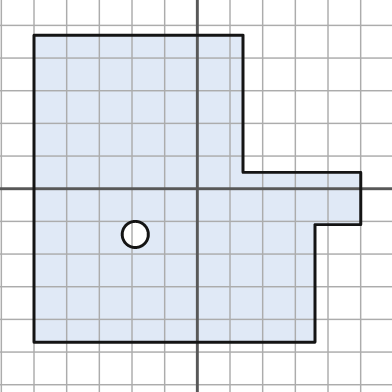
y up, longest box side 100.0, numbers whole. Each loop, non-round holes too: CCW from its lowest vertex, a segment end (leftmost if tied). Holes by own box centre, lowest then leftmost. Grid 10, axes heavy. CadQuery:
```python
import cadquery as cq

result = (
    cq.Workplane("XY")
    .moveTo(-50.0, -47.0)
    .lineTo(36.0, -47.0)
    .lineTo(36.0, -11.0)
    .lineTo(50.0, -11.0)
    .lineTo(50.0, 5.0)
    .lineTo(14.0, 5.0)
    .lineTo(14.0, 47.0)
    .lineTo(-50.0, 47.0)
    .close()
    .moveTo(-19.0, -14.0)
    .circle(4.0)
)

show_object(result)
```